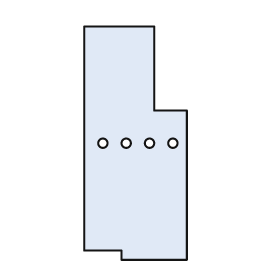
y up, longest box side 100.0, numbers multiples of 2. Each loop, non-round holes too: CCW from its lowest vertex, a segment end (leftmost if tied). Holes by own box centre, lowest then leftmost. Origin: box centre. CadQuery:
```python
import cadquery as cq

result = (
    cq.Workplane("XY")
    .moveTo(-6.0, -50.0)
    .lineTo(22.0, -50.0)
    .lineTo(22.0, 14.0)
    .lineTo(8.0, 14.0)
    .lineTo(8.0, 50.0)
    .lineTo(-22.0, 50.0)
    .lineTo(-22.0, -46.0)
    .lineTo(-6.0, -46.0)
    .close()
    .moveTo(-14.0, 0.0)
    .circle(2.0)
    .moveTo(-4.0, 0.0)
    .circle(2.0)
    .moveTo(6.0, 0.0)
    .circle(2.0)
    .moveTo(16.0, 0.0)
    .circle(2.0)
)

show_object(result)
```